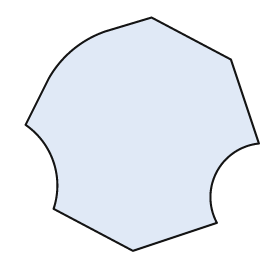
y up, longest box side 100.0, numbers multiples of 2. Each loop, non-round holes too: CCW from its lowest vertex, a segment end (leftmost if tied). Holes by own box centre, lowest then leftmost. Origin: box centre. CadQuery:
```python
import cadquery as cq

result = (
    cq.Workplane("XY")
    .moveTo(-4.0, -50.0)
    .lineTo(32.0, -38.0)
    .threePointArc((32.0, -16.0), (50.0, -4.0))
    .lineTo(38.0, 32.0)
    .lineTo(4.0, 50.0)
    .lineTo(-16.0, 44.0)
    .threePointArc((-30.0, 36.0), (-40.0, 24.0))
    .lineTo(-50.0, 4.0)
    .threePointArc((-38.0, -12.0), (-38.0, -32.0))
    .close()
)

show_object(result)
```